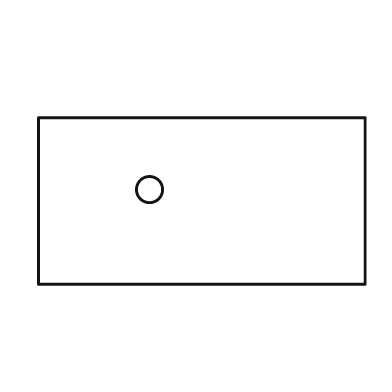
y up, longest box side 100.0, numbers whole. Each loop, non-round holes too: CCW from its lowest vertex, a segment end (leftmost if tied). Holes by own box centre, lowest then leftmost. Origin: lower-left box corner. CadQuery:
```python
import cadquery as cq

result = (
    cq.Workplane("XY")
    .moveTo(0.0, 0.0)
    .lineTo(100.0, 0.0)
    .lineTo(100.0, 51.0)
    .lineTo(0.0, 51.0)
    .close()
    .moveTo(34.0, 29.0)
    .circle(4.0)
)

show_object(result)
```